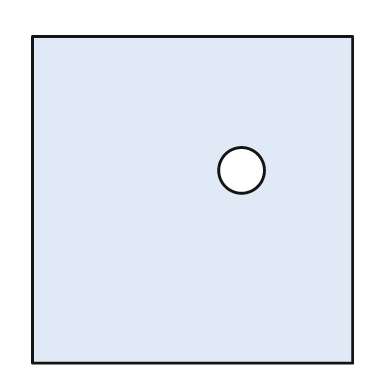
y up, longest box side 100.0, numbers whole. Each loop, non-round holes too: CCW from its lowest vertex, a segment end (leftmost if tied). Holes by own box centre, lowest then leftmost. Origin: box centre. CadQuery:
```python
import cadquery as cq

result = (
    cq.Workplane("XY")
    .moveTo(-49.0, -50.0)
    .lineTo(49.0, -50.0)
    .lineTo(49.0, 50.0)
    .lineTo(-49.0, 50.0)
    .close()
    .moveTo(15.0, 9.0)
    .circle(7.0)
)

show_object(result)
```